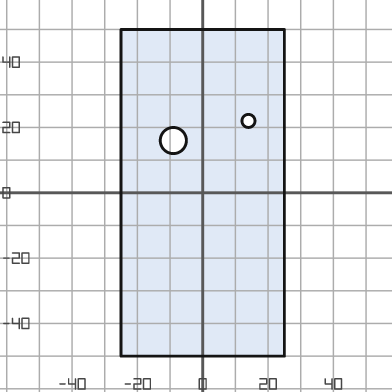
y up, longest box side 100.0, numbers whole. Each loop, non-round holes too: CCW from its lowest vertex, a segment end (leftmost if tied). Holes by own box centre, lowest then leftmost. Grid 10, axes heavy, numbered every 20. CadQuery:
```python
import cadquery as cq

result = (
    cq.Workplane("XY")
    .moveTo(-25.0, -50.0)
    .lineTo(25.0, -50.0)
    .lineTo(25.0, 50.0)
    .lineTo(-25.0, 50.0)
    .close()
    .moveTo(-9.0, 16.0)
    .circle(4.0)
    .moveTo(14.0, 22.0)
    .circle(2.0)
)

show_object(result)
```